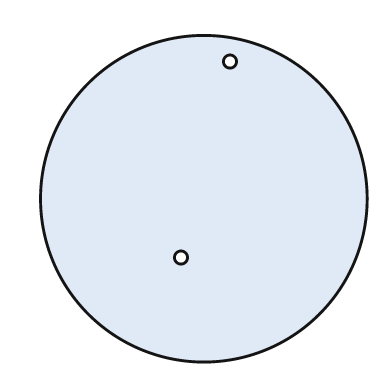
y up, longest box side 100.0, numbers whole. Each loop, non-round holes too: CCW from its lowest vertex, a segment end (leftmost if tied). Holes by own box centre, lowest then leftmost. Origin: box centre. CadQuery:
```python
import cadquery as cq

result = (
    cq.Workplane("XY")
    .moveTo(0.0, 0.0)
    .circle(50.0)
    .moveTo(-7.0, -18.0)
    .circle(2.0)
    .moveTo(8.0, 42.0)
    .circle(2.0)
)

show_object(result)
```